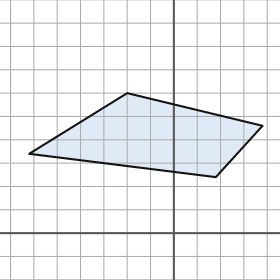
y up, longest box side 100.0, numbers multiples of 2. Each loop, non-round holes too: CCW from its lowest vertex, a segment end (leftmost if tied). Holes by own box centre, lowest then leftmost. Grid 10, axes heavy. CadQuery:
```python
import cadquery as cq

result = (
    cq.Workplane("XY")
    .moveTo(18.0, 24.0)
    .lineTo(38.0, 46.0)
    .lineTo(-20.0, 60.0)
    .lineTo(-62.0, 34.0)
    .close()
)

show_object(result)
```